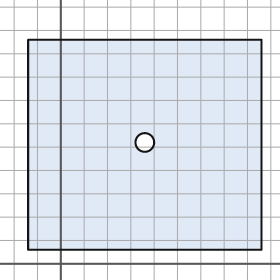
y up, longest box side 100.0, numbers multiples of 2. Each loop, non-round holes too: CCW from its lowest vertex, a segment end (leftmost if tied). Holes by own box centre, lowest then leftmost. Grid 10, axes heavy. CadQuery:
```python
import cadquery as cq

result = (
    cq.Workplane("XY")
    .moveTo(-14.0, 6.0)
    .lineTo(86.0, 6.0)
    .lineTo(86.0, 96.0)
    .lineTo(-14.0, 96.0)
    .close()
    .moveTo(36.0, 52.0)
    .circle(4.0)
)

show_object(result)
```